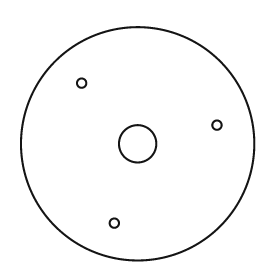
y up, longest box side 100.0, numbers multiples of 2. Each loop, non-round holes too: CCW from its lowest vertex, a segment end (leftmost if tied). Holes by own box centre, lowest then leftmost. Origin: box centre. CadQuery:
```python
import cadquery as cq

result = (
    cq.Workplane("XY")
    .moveTo(0.0, 0.0)
    .circle(50.0)
    .moveTo(-10.0, -34.0)
    .circle(2.0)
    .moveTo(0.0, 0.0)
    .circle(8.0)
    .moveTo(34.0, 8.0)
    .circle(2.0)
    .moveTo(-24.0, 26.0)
    .circle(2.0)
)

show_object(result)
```